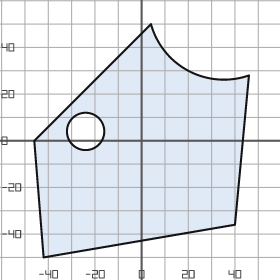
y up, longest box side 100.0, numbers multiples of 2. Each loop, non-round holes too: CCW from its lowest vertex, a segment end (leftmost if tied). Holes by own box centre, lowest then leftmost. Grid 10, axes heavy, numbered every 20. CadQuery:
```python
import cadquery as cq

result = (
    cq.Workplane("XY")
    .moveTo(-42.0, -50.0)
    .lineTo(40.0, -36.0)
    .lineTo(46.0, 28.0)
    .threePointArc((20.0, 30.0), (4.0, 50.0))
    .lineTo(-46.0, 0.0)
    .close()
    .moveTo(-24.0, 4.0)
    .circle(8.0)
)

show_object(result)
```